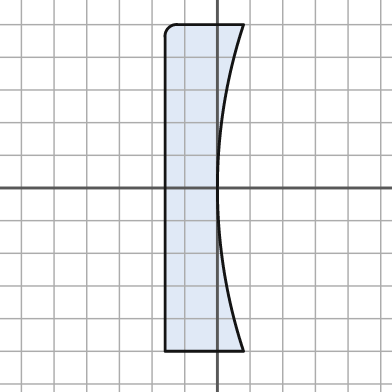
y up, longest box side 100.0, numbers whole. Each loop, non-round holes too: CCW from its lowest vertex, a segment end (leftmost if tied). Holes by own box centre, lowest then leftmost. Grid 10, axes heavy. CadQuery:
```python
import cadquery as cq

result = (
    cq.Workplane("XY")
    .moveTo(-16.0, -50.0)
    .lineTo(8.0, -50.0)
    .threePointArc((0.0, 0.0), (8.0, 50.0))
    .lineTo(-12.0, 50.0)
    .threePointArc((-15.0, 49.0), (-16.0, 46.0))
    .close()
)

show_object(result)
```